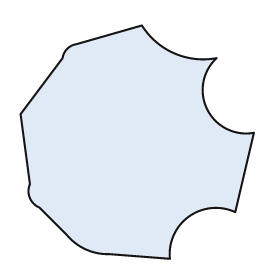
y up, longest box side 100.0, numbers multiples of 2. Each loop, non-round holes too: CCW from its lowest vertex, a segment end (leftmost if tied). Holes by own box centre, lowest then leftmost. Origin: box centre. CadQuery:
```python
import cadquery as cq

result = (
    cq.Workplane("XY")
    .moveTo(14.0, -50.0)
    .threePointArc((22.0, -32.0), (42.0, -30.0))
    .lineTo(50.0, 4.0)
    .threePointArc((30.0, 14.0), (34.0, 36.0))
    .threePointArc((16.0, 38.0), (2.0, 50.0))
    .lineTo(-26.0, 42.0)
    .threePointArc((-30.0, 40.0), (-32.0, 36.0))
    .lineTo(-50.0, 12.0)
    .lineTo(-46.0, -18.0)
    .threePointArc((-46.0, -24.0), (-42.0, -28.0))
    .lineTo(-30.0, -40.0)
    .threePointArc((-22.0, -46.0), (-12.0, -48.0))
    .close()
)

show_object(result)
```